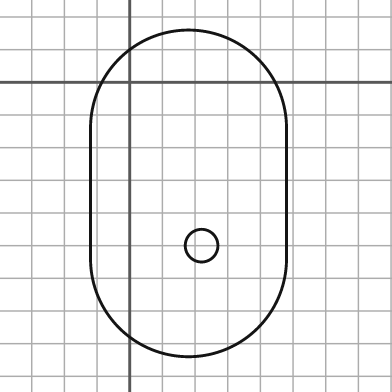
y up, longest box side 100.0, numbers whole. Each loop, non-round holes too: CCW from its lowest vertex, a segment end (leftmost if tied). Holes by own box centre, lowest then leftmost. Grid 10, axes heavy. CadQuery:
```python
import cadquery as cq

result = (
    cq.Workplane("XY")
    .moveTo(-12.0, -54.0)
    .threePointArc((18.0, -84.0), (48.0, -54.0))
    .lineTo(48.0, -14.0)
    .threePointArc((18.0, 16.0), (-12.0, -14.0))
    .close()
    .moveTo(22.0, -50.0)
    .circle(5.0)
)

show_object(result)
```